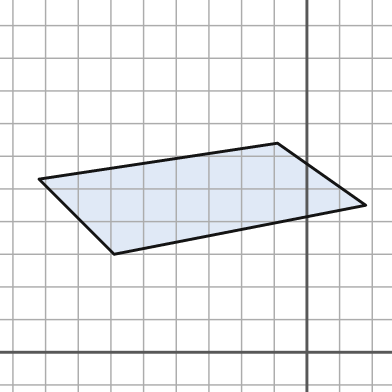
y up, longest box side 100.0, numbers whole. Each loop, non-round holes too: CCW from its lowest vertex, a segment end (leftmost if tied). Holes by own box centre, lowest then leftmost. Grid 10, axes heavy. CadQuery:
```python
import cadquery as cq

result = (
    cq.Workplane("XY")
    .moveTo(-59.0, 30.0)
    .lineTo(18.0, 45.0)
    .lineTo(-9.0, 64.0)
    .lineTo(-82.0, 53.0)
    .close()
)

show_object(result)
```